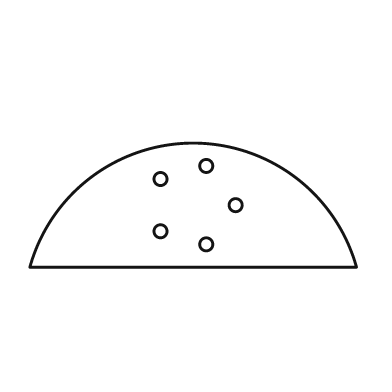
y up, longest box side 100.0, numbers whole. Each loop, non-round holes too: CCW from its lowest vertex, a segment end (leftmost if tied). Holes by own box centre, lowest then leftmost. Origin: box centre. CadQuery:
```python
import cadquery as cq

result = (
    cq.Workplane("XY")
    .moveTo(-50.0, -19.0)
    .lineTo(50.0, -19.0)
    .threePointArc((0.0, 19.0), (-50.0, -19.0))
    .close()
    .moveTo(4.0, -12.0)
    .circle(2.0)
    .moveTo(-10.0, -8.0)
    .circle(2.0)
    .moveTo(13.0, 0.0)
    .circle(2.0)
    .moveTo(-10.0, 8.0)
    .circle(2.0)
    .moveTo(4.0, 12.0)
    .circle(2.0)
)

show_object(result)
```